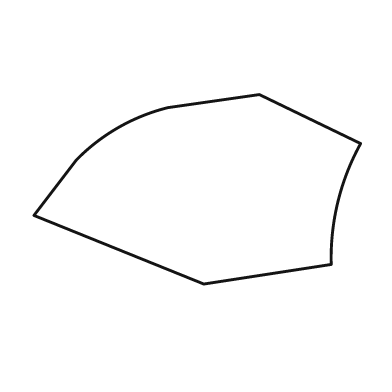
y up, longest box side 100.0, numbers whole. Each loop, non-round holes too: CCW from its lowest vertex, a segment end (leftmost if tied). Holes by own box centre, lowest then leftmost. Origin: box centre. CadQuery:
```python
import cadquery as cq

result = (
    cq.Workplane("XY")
    .moveTo(2.0, -29.0)
    .lineTo(41.0, -23.0)
    .threePointArc((43.0, -4.0), (50.0, 14.0))
    .lineTo(19.0, 29.0)
    .lineTo(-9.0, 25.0)
    .threePointArc((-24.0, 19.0), (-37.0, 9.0))
    .lineTo(-50.0, -8.0)
    .close()
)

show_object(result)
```